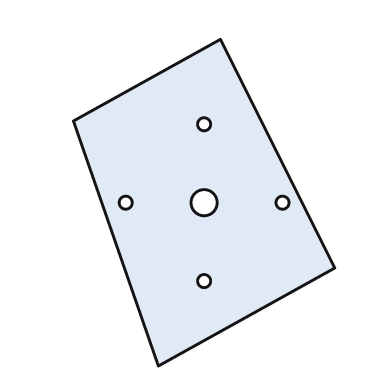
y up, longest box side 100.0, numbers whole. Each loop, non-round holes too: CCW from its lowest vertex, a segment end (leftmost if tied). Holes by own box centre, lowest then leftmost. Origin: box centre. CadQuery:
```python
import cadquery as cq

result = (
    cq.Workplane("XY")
    .moveTo(-14.0, -50.0)
    .lineTo(40.0, -20.0)
    .lineTo(5.0, 50.0)
    .lineTo(-40.0, 25.0)
    .close()
    .moveTo(0.0, -24.0)
    .circle(2.0)
    .moveTo(-24.0, 0.0)
    .circle(2.0)
    .moveTo(0.0, 0.0)
    .circle(4.0)
    .moveTo(24.0, 0.0)
    .circle(2.0)
    .moveTo(0.0, 24.0)
    .circle(2.0)
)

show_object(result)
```